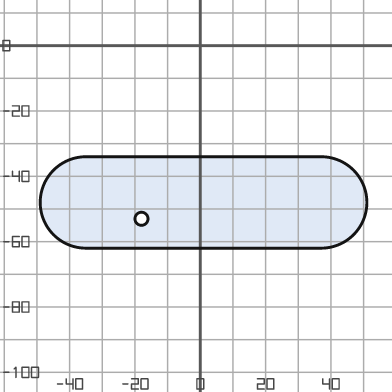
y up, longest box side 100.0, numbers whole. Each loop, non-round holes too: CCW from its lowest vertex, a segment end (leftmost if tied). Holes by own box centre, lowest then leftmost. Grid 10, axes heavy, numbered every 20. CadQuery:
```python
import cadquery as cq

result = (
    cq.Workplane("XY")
    .moveTo(-35.0, -62.0)
    .lineTo(37.0, -62.0)
    .threePointArc((51.0, -48.0), (37.0, -34.0))
    .lineTo(-35.0, -34.0)
    .threePointArc((-49.0, -48.0), (-35.0, -62.0))
    .close()
    .moveTo(-18.0, -53.0)
    .circle(2.0)
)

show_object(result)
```